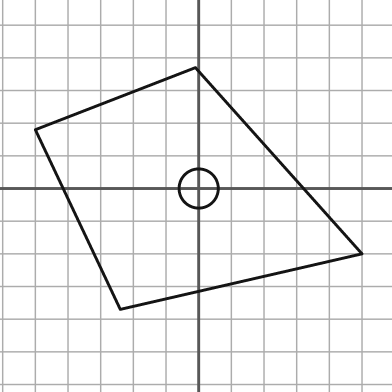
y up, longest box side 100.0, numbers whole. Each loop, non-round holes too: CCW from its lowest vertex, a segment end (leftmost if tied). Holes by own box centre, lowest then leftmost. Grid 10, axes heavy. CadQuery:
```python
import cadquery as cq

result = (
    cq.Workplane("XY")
    .moveTo(-24.0, -37.0)
    .lineTo(50.0, -20.0)
    .lineTo(-1.0, 37.0)
    .lineTo(-50.0, 18.0)
    .close()
    .moveTo(0.0, 0.0)
    .circle(6.0)
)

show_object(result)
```